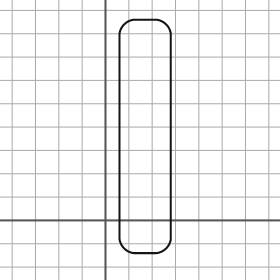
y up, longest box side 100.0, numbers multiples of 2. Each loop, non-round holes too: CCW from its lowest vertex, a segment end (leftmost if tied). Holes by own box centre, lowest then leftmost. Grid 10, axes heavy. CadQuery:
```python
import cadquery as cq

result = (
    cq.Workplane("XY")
    .moveTo(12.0, -14.0)
    .lineTo(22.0, -14.0)
    .threePointArc((26.0, -12.0), (28.0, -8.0))
    .lineTo(28.0, 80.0)
    .threePointArc((26.0, 84.0), (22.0, 86.0))
    .lineTo(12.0, 86.0)
    .threePointArc((8.0, 84.0), (6.0, 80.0))
    .lineTo(6.0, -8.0)
    .threePointArc((8.0, -12.0), (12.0, -14.0))
    .close()
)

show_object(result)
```